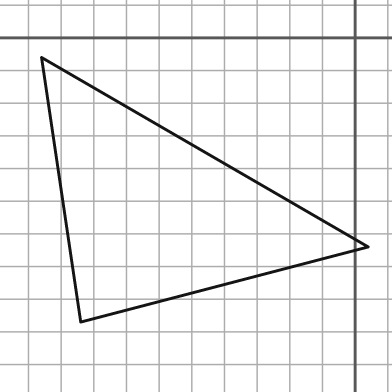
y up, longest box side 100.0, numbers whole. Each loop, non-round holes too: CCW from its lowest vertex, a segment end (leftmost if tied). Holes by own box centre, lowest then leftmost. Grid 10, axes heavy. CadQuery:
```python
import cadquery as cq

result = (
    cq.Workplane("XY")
    .moveTo(-84.0, -87.0)
    .lineTo(4.0, -64.0)
    .lineTo(-96.0, -6.0)
    .close()
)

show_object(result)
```